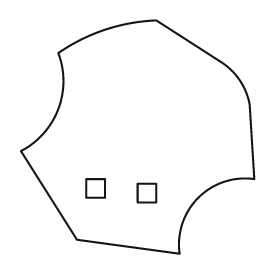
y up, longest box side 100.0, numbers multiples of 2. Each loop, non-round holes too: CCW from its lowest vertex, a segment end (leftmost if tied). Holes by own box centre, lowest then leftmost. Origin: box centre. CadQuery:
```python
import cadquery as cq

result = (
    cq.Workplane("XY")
    .moveTo(18.0, -50.0)
    .threePointArc((26.0, -26.0), (50.0, -18.0))
    .lineTo(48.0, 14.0)
    .threePointArc((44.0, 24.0), (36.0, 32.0))
    .lineTo(8.0, 50.0)
    .threePointArc((-14.0, 46.0), (-34.0, 36.0))
    .threePointArc((-34.0, 12.0), (-50.0, -6.0))
    .lineTo(-26.0, -44.0)
    .close()
    .moveTo(0.0, -28.0)
    .lineTo(8.0, -28.0)
    .lineTo(8.0, -20.0)
    .lineTo(0.0, -20.0)
    .close()
    .moveTo(-22.0, -26.0)
    .lineTo(-14.0, -26.0)
    .lineTo(-14.0, -18.0)
    .lineTo(-22.0, -18.0)
    .close()
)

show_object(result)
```